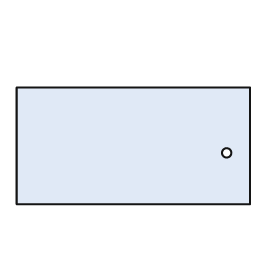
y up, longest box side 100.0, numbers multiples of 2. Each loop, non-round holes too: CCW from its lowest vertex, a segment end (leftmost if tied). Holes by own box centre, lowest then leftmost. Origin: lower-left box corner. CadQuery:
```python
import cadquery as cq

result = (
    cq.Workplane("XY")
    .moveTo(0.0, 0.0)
    .lineTo(100.0, 0.0)
    .lineTo(100.0, 50.0)
    .lineTo(0.0, 50.0)
    .close()
    .moveTo(90.0, 22.0)
    .circle(2.0)
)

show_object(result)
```